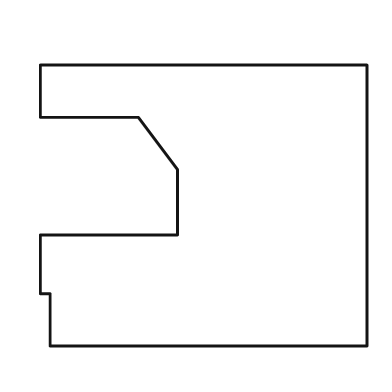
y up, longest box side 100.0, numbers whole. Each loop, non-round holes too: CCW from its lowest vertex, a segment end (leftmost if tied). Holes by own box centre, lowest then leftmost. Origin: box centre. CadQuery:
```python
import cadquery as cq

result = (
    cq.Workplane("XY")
    .moveTo(-47.0, -43.0)
    .lineTo(50.0, -43.0)
    .lineTo(50.0, 43.0)
    .lineTo(-50.0, 43.0)
    .lineTo(-50.0, 27.0)
    .lineTo(-20.0, 27.0)
    .lineTo(-8.0, 11.0)
    .lineTo(-8.0, -9.0)
    .lineTo(-50.0, -9.0)
    .lineTo(-50.0, -27.0)
    .lineTo(-47.0, -27.0)
    .close()
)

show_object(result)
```